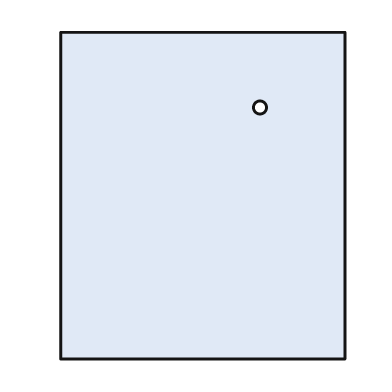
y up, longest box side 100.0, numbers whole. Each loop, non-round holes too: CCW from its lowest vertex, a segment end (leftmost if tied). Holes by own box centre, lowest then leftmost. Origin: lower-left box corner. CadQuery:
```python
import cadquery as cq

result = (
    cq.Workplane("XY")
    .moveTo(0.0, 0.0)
    .lineTo(87.0, 0.0)
    .lineTo(87.0, 100.0)
    .lineTo(0.0, 100.0)
    .close()
    .moveTo(61.0, 77.0)
    .circle(2.0)
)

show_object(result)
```